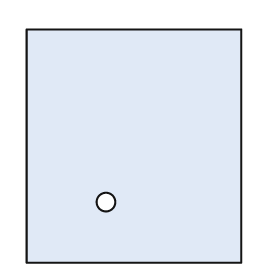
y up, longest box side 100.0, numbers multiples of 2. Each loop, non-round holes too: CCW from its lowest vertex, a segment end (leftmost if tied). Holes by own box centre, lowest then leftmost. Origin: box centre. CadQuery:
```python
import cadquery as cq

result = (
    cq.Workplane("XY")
    .moveTo(-46.0, -50.0)
    .lineTo(46.0, -50.0)
    .lineTo(46.0, 50.0)
    .lineTo(-46.0, 50.0)
    .close()
    .moveTo(-12.0, -24.0)
    .circle(4.0)
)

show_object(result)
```